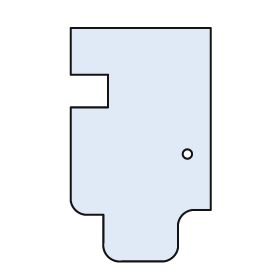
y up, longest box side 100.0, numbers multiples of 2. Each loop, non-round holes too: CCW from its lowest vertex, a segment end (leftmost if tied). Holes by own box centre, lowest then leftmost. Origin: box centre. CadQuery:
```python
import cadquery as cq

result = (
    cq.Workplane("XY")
    .moveTo(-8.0, -50.0)
    .lineTo(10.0, -50.0)
    .threePointArc((14.0, -48.0), (16.0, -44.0))
    .lineTo(16.0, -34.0)
    .threePointArc((18.0, -30.0), (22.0, -28.0))
    .lineTo(30.0, -28.0)
    .lineTo(30.0, 50.0)
    .lineTo(-30.0, 50.0)
    .lineTo(-30.0, 30.0)
    .lineTo(-14.0, 30.0)
    .lineTo(-14.0, 16.0)
    .lineTo(-30.0, 16.0)
    .lineTo(-30.0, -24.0)
    .threePointArc((-28.0, -28.0), (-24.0, -30.0))
    .lineTo(-16.0, -30.0)
    .lineTo(-16.0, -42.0)
    .threePointArc((-14.0, -48.0), (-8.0, -50.0))
    .close()
    .moveTo(20.0, -4.0)
    .circle(2.0)
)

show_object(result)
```